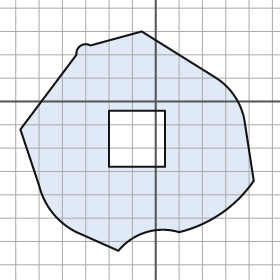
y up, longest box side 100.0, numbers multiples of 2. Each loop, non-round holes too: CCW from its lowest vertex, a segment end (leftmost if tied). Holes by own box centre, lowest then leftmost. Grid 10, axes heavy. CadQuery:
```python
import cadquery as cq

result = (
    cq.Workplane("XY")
    .moveTo(-16.0, -64.0)
    .threePointArc((-4.0, -56.0), (10.0, -56.0))
    .threePointArc((28.0, -48.0), (42.0, -34.0))
    .lineTo(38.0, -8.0)
    .threePointArc((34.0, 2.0), (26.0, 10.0))
    .lineTo(-6.0, 30.0)
    .lineTo(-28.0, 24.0)
    .threePointArc((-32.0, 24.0), (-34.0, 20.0))
    .lineTo(-58.0, -12.0)
    .lineTo(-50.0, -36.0)
    .threePointArc((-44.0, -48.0), (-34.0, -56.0))
    .close()
    .moveTo(-20.0, -28.0)
    .lineTo(4.0, -28.0)
    .lineTo(4.0, -4.0)
    .lineTo(-20.0, -4.0)
    .close()
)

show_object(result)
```